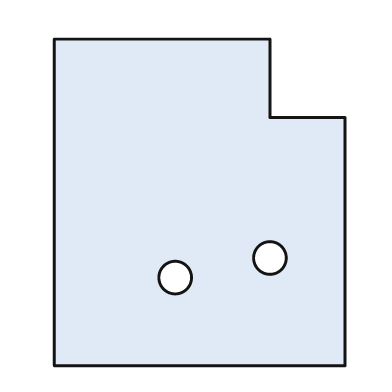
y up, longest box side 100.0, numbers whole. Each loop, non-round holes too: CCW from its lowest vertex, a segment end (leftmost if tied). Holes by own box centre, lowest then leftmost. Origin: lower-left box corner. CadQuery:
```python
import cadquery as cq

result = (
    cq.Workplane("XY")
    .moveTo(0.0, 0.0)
    .lineTo(89.0, 0.0)
    .lineTo(89.0, 76.0)
    .lineTo(66.0, 76.0)
    .lineTo(66.0, 100.0)
    .lineTo(0.0, 100.0)
    .close()
    .moveTo(37.0, 27.0)
    .circle(5.0)
    .moveTo(66.0, 33.0)
    .circle(5.0)
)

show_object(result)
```